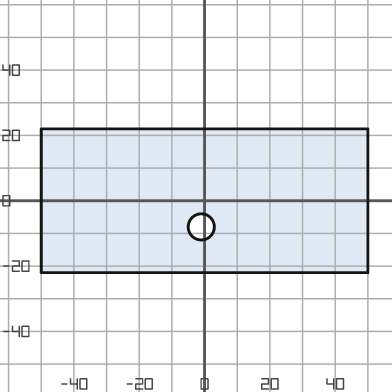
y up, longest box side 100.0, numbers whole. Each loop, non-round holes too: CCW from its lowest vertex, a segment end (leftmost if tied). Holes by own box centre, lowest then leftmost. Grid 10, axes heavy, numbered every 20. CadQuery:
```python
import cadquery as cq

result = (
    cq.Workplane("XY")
    .moveTo(-50.0, -22.0)
    .lineTo(50.0, -22.0)
    .lineTo(50.0, 22.0)
    .lineTo(-50.0, 22.0)
    .close()
    .moveTo(-1.0, -8.0)
    .circle(4.0)
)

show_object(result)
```